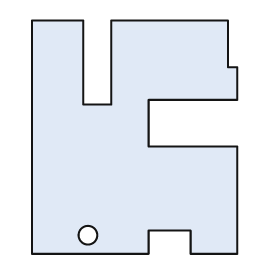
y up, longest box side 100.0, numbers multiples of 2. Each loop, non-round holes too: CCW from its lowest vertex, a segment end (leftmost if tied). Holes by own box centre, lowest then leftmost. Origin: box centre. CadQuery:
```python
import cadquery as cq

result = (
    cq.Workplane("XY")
    .moveTo(-44.0, -50.0)
    .lineTo(6.0, -50.0)
    .lineTo(6.0, -40.0)
    .lineTo(24.0, -40.0)
    .lineTo(24.0, -50.0)
    .lineTo(44.0, -50.0)
    .lineTo(44.0, -4.0)
    .lineTo(6.0, -4.0)
    .lineTo(6.0, 16.0)
    .lineTo(44.0, 16.0)
    .lineTo(44.0, 30.0)
    .lineTo(40.0, 30.0)
    .lineTo(40.0, 50.0)
    .lineTo(-10.0, 50.0)
    .lineTo(-10.0, 14.0)
    .lineTo(-22.0, 14.0)
    .lineTo(-22.0, 50.0)
    .lineTo(-44.0, 50.0)
    .close()
    .moveTo(-20.0, -42.0)
    .circle(4.0)
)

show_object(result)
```